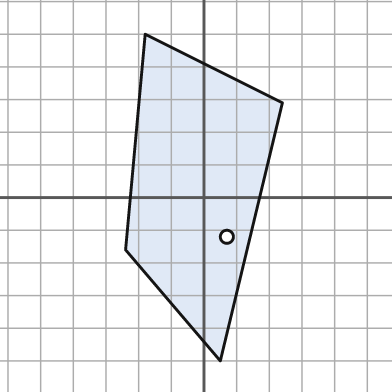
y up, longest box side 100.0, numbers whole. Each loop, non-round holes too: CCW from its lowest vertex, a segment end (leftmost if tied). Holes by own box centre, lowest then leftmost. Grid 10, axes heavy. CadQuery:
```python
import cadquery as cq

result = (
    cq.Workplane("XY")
    .moveTo(5.0, -50.0)
    .lineTo(24.0, 29.0)
    .lineTo(-18.0, 50.0)
    .lineTo(-24.0, -16.0)
    .close()
    .moveTo(7.0, -12.0)
    .circle(2.0)
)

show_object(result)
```